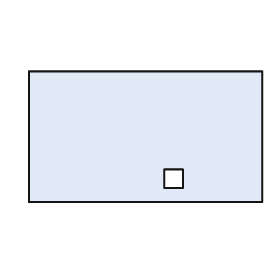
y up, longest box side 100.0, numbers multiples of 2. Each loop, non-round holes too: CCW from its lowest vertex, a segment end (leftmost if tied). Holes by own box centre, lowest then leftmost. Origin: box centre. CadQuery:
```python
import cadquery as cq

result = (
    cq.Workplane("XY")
    .moveTo(-50.0, -28.0)
    .lineTo(50.0, -28.0)
    .lineTo(50.0, 28.0)
    .lineTo(-50.0, 28.0)
    .close()
    .moveTo(8.0, -22.0)
    .lineTo(16.0, -22.0)
    .lineTo(16.0, -14.0)
    .lineTo(8.0, -14.0)
    .close()
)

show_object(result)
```